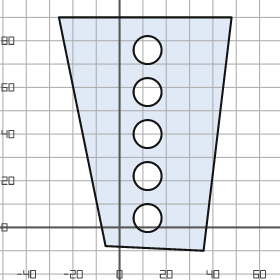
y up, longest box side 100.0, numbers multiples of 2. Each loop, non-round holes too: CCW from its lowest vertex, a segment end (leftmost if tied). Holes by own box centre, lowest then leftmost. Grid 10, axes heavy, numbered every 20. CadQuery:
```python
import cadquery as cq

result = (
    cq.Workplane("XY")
    .moveTo(36.0, -10.0)
    .lineTo(48.0, 90.0)
    .lineTo(-26.0, 90.0)
    .lineTo(-6.0, -8.0)
    .close()
    .moveTo(12.0, 4.0)
    .circle(6.0)
    .moveTo(12.0, 22.0)
    .circle(6.0)
    .moveTo(12.0, 40.0)
    .circle(6.0)
    .moveTo(12.0, 58.0)
    .circle(6.0)
    .moveTo(12.0, 76.0)
    .circle(6.0)
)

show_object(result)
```